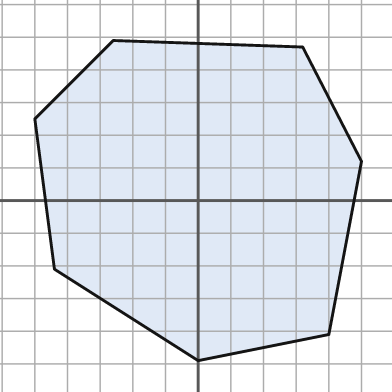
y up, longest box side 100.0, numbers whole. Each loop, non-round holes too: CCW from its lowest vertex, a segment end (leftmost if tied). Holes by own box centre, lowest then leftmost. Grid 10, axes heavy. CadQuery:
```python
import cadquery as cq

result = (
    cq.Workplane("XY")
    .moveTo(0.0, -49.0)
    .lineTo(40.0, -41.0)
    .lineTo(50.0, 12.0)
    .lineTo(32.0, 47.0)
    .lineTo(-26.0, 49.0)
    .lineTo(-50.0, 25.0)
    .lineTo(-44.0, -21.0)
    .close()
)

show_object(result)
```